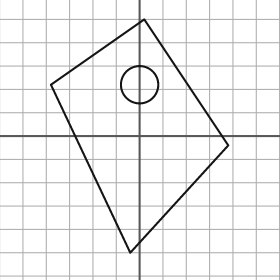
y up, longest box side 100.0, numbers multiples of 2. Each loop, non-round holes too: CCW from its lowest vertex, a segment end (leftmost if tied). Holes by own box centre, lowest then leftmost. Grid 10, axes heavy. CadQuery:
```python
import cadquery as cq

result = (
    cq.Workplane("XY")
    .moveTo(-4.0, -50.0)
    .lineTo(38.0, -4.0)
    .lineTo(2.0, 50.0)
    .lineTo(-38.0, 22.0)
    .close()
    .moveTo(0.0, 22.0)
    .circle(8.0)
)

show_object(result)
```